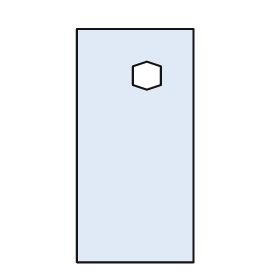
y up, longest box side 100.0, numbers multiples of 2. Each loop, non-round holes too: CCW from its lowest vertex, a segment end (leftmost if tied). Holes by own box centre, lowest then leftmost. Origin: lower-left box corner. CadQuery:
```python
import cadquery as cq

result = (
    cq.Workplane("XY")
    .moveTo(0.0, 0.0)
    .lineTo(50.0, 0.0)
    .lineTo(50.0, 100.0)
    .lineTo(0.0, 100.0)
    .close()
    .moveTo(30.0, 74.0)
    .lineTo(36.0, 76.0)
    .lineTo(36.0, 84.0)
    .lineTo(30.0, 86.0)
    .lineTo(24.0, 84.0)
    .lineTo(24.0, 76.0)
    .close()
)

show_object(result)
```